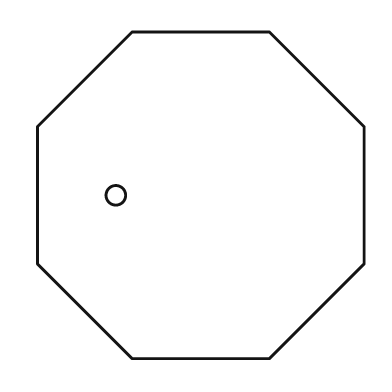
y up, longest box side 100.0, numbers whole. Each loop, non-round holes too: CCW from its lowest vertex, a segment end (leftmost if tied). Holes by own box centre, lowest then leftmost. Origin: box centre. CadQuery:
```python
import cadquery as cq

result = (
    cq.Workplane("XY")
    .moveTo(-21.0, -50.0)
    .lineTo(21.0, -50.0)
    .lineTo(50.0, -21.0)
    .lineTo(50.0, 21.0)
    .lineTo(21.0, 50.0)
    .lineTo(-21.0, 50.0)
    .lineTo(-50.0, 21.0)
    .lineTo(-50.0, -21.0)
    .close()
    .moveTo(-26.0, 0.0)
    .circle(3.0)
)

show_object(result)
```